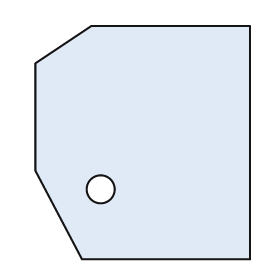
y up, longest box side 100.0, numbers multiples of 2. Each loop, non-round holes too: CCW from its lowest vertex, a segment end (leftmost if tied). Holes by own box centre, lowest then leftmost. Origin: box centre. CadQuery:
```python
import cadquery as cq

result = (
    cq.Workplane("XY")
    .moveTo(-26.0, -50.0)
    .lineTo(46.0, -50.0)
    .lineTo(46.0, 50.0)
    .lineTo(-22.0, 50.0)
    .lineTo(-46.0, 34.0)
    .lineTo(-46.0, -12.0)
    .close()
    .moveTo(-18.0, -20.0)
    .circle(6.0)
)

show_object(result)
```